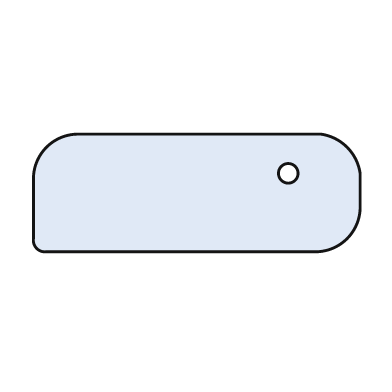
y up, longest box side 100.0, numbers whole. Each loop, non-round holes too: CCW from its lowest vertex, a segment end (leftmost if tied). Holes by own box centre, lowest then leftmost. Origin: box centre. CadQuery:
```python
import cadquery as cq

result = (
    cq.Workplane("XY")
    .moveTo(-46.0, -18.0)
    .lineTo(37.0, -18.0)
    .threePointArc((46.0, -14.0), (50.0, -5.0))
    .lineTo(50.0, 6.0)
    .threePointArc((46.0, 14.0), (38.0, 18.0))
    .lineTo(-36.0, 18.0)
    .threePointArc((-46.0, 14.0), (-50.0, 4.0))
    .lineTo(-50.0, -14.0)
    .threePointArc((-49.0, -17.0), (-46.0, -18.0))
    .close()
    .moveTo(28.0, 6.0)
    .circle(3.0)
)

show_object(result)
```